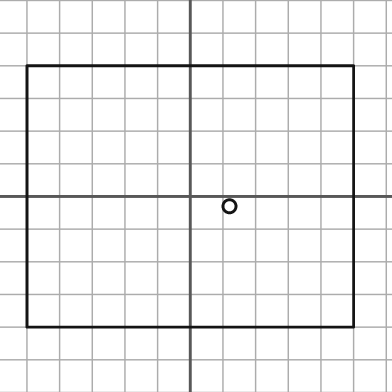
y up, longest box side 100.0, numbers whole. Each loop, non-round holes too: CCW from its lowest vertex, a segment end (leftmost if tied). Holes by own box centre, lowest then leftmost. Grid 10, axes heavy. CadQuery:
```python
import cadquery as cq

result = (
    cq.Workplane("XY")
    .moveTo(-50.0, -40.0)
    .lineTo(50.0, -40.0)
    .lineTo(50.0, 40.0)
    .lineTo(-50.0, 40.0)
    .close()
    .moveTo(12.0, -3.0)
    .circle(2.0)
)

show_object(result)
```